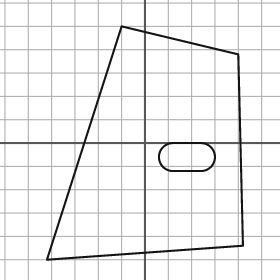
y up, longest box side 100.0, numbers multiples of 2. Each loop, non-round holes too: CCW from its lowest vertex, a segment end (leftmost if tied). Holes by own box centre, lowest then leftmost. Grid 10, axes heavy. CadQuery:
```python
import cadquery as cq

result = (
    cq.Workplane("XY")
    .moveTo(-42.0, -50.0)
    .lineTo(42.0, -44.0)
    .lineTo(40.0, 38.0)
    .lineTo(-10.0, 50.0)
    .close()
    .moveTo(12.0, -12.0)
    .lineTo(24.0, -12.0)
    .threePointArc((30.0, -6.0), (24.0, 0.0))
    .lineTo(12.0, 0.0)
    .threePointArc((6.0, -6.0), (12.0, -12.0))
    .close()
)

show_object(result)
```